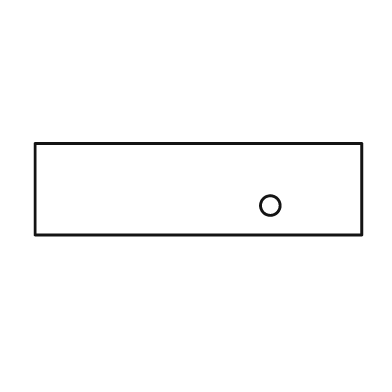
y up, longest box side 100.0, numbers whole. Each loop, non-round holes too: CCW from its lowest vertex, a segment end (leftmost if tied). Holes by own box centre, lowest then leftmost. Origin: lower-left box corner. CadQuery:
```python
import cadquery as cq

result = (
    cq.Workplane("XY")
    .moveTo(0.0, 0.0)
    .lineTo(100.0, 0.0)
    .lineTo(100.0, 28.0)
    .lineTo(0.0, 28.0)
    .close()
    .moveTo(72.0, 9.0)
    .circle(3.0)
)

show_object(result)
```